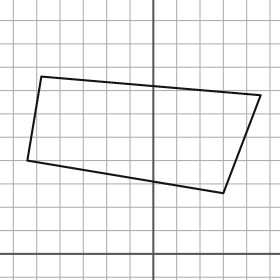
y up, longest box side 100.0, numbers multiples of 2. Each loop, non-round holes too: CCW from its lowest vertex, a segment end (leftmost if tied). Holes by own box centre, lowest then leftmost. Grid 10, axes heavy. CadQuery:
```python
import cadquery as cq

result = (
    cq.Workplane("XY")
    .moveTo(30.0, 26.0)
    .lineTo(46.0, 68.0)
    .lineTo(-48.0, 76.0)
    .lineTo(-54.0, 40.0)
    .close()
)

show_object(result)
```